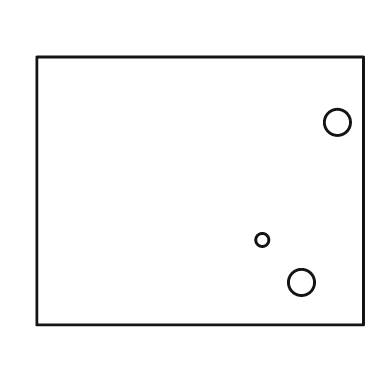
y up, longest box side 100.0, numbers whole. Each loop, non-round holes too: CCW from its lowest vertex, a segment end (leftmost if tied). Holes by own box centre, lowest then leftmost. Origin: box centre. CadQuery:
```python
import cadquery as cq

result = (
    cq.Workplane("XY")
    .moveTo(-50.0, -41.0)
    .lineTo(50.0, -41.0)
    .lineTo(50.0, 41.0)
    .lineTo(-50.0, 41.0)
    .close()
    .moveTo(31.0, -28.0)
    .circle(4.0)
    .moveTo(19.0, -15.0)
    .circle(2.0)
    .moveTo(42.0, 21.0)
    .circle(4.0)
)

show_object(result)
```